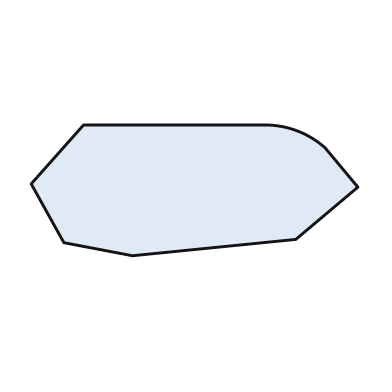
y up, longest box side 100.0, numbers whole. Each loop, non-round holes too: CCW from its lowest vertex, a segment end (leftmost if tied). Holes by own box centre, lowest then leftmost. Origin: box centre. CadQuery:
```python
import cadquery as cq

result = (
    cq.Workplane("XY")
    .moveTo(-19.0, -20.0)
    .lineTo(31.0, -15.0)
    .lineTo(50.0, 1.0)
    .lineTo(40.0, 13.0)
    .threePointArc((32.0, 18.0), (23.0, 20.0))
    .lineTo(-34.0, 20.0)
    .lineTo(-50.0, 2.0)
    .lineTo(-40.0, -16.0)
    .close()
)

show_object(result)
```